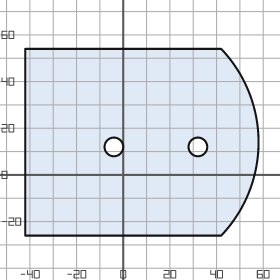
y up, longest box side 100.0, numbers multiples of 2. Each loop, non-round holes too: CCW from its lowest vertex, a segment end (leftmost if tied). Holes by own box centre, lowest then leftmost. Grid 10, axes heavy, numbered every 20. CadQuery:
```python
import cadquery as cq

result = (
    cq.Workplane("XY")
    .moveTo(-42.0, -26.0)
    .lineTo(42.0, -26.0)
    .threePointArc((58.0, 14.0), (42.0, 54.0))
    .lineTo(-42.0, 54.0)
    .close()
    .moveTo(-4.0, 12.0)
    .circle(4.0)
    .moveTo(32.0, 12.0)
    .circle(4.0)
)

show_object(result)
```